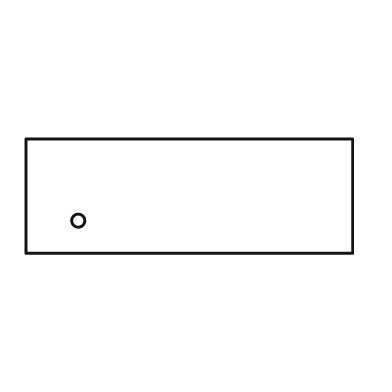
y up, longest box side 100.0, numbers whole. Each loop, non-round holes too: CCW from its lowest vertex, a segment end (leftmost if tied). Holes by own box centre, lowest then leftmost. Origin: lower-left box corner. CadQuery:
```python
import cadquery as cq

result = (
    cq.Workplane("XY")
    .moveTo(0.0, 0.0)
    .lineTo(100.0, 0.0)
    .lineTo(100.0, 35.0)
    .lineTo(0.0, 35.0)
    .close()
    .moveTo(16.0, 10.0)
    .circle(2.0)
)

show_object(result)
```